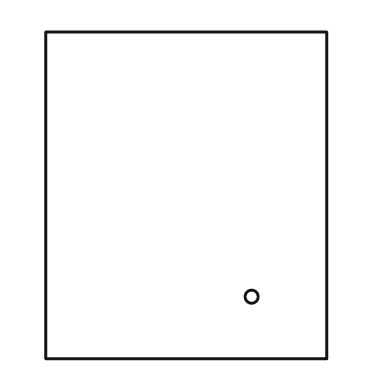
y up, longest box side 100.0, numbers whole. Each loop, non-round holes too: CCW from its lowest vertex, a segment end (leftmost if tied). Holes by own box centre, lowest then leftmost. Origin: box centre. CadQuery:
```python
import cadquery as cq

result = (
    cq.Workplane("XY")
    .moveTo(-43.0, -50.0)
    .lineTo(43.0, -50.0)
    .lineTo(43.0, 50.0)
    .lineTo(-43.0, 50.0)
    .close()
    .moveTo(20.0, -31.0)
    .circle(2.0)
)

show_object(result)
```